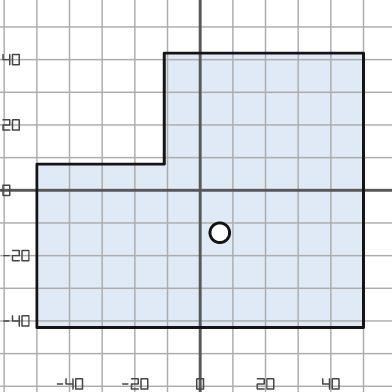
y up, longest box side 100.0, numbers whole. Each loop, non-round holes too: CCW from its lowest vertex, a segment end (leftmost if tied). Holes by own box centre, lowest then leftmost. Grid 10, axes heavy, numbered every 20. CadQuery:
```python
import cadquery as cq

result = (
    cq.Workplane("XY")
    .moveTo(-50.0, -42.0)
    .lineTo(50.0, -42.0)
    .lineTo(50.0, 42.0)
    .lineTo(-11.0, 42.0)
    .lineTo(-11.0, 8.0)
    .lineTo(-50.0, 8.0)
    .close()
    .moveTo(6.0, -13.0)
    .circle(3.0)
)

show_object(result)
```